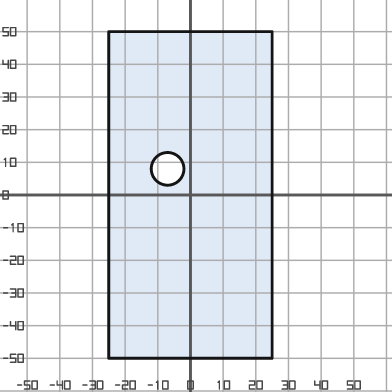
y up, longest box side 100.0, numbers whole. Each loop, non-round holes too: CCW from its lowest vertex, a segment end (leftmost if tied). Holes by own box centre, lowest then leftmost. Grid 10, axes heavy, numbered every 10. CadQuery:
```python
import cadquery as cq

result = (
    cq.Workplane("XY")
    .moveTo(-25.0, -50.0)
    .lineTo(25.0, -50.0)
    .lineTo(25.0, 50.0)
    .lineTo(-25.0, 50.0)
    .close()
    .moveTo(-7.0, 8.0)
    .circle(5.0)
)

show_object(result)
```